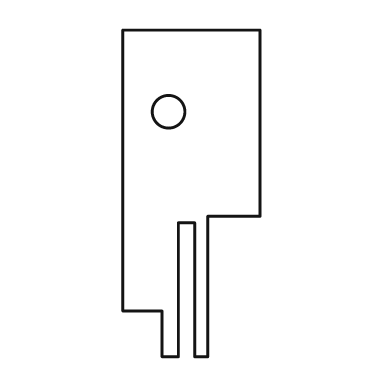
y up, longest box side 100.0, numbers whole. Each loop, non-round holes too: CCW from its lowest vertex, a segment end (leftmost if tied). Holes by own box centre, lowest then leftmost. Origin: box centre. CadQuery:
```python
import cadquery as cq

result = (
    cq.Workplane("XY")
    .moveTo(-9.0, -50.0)
    .lineTo(-4.0, -50.0)
    .lineTo(-4.0, -9.0)
    .lineTo(1.0, -9.0)
    .lineTo(1.0, -50.0)
    .lineTo(5.0, -50.0)
    .lineTo(5.0, -7.0)
    .lineTo(21.0, -7.0)
    .lineTo(21.0, 50.0)
    .lineTo(-21.0, 50.0)
    .lineTo(-21.0, -36.0)
    .lineTo(-9.0, -36.0)
    .close()
    .moveTo(-7.0, 25.0)
    .circle(5.0)
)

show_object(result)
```